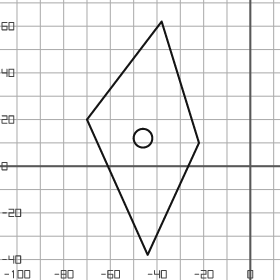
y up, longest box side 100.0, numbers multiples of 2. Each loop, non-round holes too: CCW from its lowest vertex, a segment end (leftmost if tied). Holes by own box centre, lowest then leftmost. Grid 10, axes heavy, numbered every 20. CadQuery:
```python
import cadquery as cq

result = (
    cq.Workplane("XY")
    .moveTo(-44.0, -38.0)
    .lineTo(-22.0, 10.0)
    .lineTo(-38.0, 62.0)
    .lineTo(-70.0, 20.0)
    .close()
    .moveTo(-46.0, 12.0)
    .circle(4.0)
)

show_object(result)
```